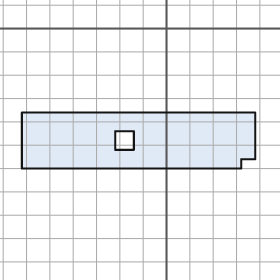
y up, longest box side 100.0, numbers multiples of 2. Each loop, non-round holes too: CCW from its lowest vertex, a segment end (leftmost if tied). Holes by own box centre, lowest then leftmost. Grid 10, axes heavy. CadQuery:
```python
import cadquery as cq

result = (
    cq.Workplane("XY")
    .moveTo(-62.0, -60.0)
    .lineTo(32.0, -60.0)
    .lineTo(32.0, -56.0)
    .lineTo(38.0, -56.0)
    .lineTo(38.0, -36.0)
    .lineTo(-62.0, -36.0)
    .close()
    .moveTo(-22.0, -52.0)
    .lineTo(-14.0, -52.0)
    .lineTo(-14.0, -44.0)
    .lineTo(-22.0, -44.0)
    .close()
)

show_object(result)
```